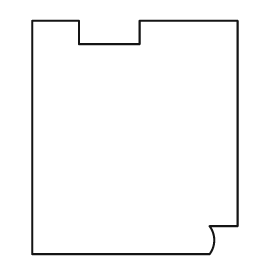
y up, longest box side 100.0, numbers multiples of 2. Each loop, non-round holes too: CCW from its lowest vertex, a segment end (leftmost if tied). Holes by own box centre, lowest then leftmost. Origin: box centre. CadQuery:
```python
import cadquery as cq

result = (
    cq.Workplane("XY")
    .moveTo(-44.0, -50.0)
    .lineTo(32.0, -50.0)
    .threePointArc((34.0, -44.0), (32.0, -38.0))
    .lineTo(44.0, -38.0)
    .lineTo(44.0, 50.0)
    .lineTo(2.0, 50.0)
    .lineTo(2.0, 40.0)
    .lineTo(-24.0, 40.0)
    .lineTo(-24.0, 50.0)
    .lineTo(-44.0, 50.0)
    .close()
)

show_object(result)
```